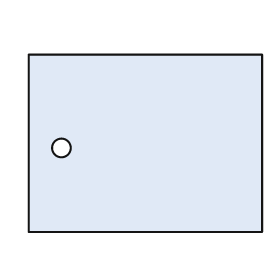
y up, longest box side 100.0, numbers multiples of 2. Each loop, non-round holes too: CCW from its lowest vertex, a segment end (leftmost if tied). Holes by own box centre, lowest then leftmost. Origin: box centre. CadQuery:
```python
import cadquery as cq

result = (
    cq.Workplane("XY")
    .moveTo(-50.0, -38.0)
    .lineTo(50.0, -38.0)
    .lineTo(50.0, 38.0)
    .lineTo(-50.0, 38.0)
    .close()
    .moveTo(-36.0, -2.0)
    .circle(4.0)
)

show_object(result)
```